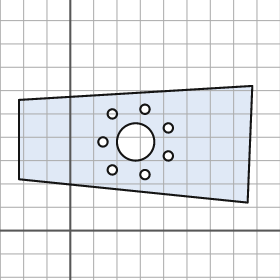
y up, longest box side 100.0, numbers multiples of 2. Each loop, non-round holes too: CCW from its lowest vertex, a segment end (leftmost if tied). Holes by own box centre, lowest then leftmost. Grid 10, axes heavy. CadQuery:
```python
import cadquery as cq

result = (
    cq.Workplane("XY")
    .moveTo(76.0, 12.0)
    .lineTo(78.0, 62.0)
    .lineTo(-22.0, 56.0)
    .lineTo(-22.0, 22.0)
    .close()
    .moveTo(32.0, 24.0)
    .circle(2.0)
    .moveTo(18.0, 26.0)
    .circle(2.0)
    .moveTo(42.0, 32.0)
    .circle(2.0)
    .moveTo(14.0, 38.0)
    .circle(2.0)
    .moveTo(28.0, 38.0)
    .circle(8.0)
    .moveTo(42.0, 44.0)
    .circle(2.0)
    .moveTo(18.0, 50.0)
    .circle(2.0)
    .moveTo(32.0, 52.0)
    .circle(2.0)
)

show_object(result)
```